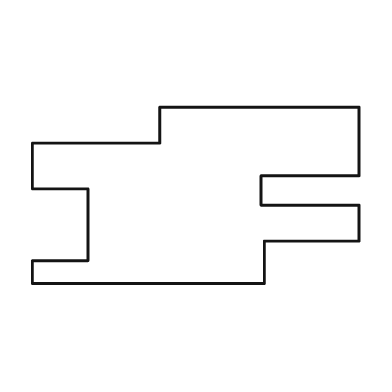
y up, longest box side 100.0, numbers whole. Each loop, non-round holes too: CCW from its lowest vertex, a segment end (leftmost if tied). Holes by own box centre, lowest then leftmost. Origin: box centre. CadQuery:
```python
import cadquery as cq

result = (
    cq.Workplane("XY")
    .moveTo(-50.0, -27.0)
    .lineTo(21.0, -27.0)
    .lineTo(21.0, -14.0)
    .lineTo(50.0, -14.0)
    .lineTo(50.0, -3.0)
    .lineTo(20.0, -3.0)
    .lineTo(20.0, 6.0)
    .lineTo(50.0, 6.0)
    .lineTo(50.0, 27.0)
    .lineTo(-11.0, 27.0)
    .lineTo(-11.0, 16.0)
    .lineTo(-50.0, 16.0)
    .lineTo(-50.0, 2.0)
    .lineTo(-33.0, 2.0)
    .lineTo(-33.0, -20.0)
    .lineTo(-50.0, -20.0)
    .close()
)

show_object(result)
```